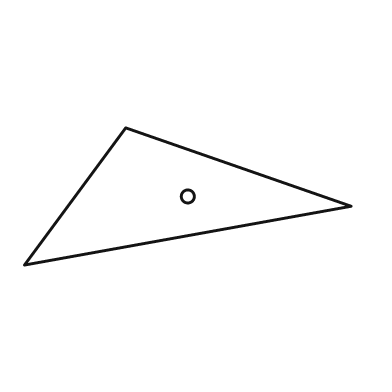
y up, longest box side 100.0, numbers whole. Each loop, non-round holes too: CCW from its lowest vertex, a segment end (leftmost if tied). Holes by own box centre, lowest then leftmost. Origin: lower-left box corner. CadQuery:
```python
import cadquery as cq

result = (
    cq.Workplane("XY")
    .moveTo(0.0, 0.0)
    .lineTo(100.0, 18.0)
    .lineTo(31.0, 42.0)
    .close()
    .moveTo(50.0, 21.0)
    .circle(2.0)
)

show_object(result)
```